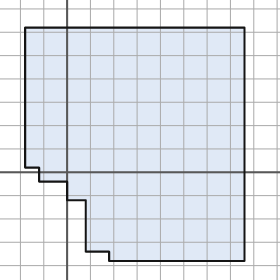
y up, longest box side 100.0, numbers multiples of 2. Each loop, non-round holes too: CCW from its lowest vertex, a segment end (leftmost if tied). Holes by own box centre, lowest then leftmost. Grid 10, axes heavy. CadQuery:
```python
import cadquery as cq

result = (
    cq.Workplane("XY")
    .moveTo(18.0, -38.0)
    .lineTo(76.0, -38.0)
    .lineTo(76.0, 62.0)
    .lineTo(-18.0, 62.0)
    .lineTo(-18.0, 2.0)
    .lineTo(-12.0, 2.0)
    .lineTo(-12.0, -4.0)
    .lineTo(0.0, -4.0)
    .lineTo(0.0, -12.0)
    .lineTo(8.0, -12.0)
    .lineTo(8.0, -34.0)
    .lineTo(18.0, -34.0)
    .close()
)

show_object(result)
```